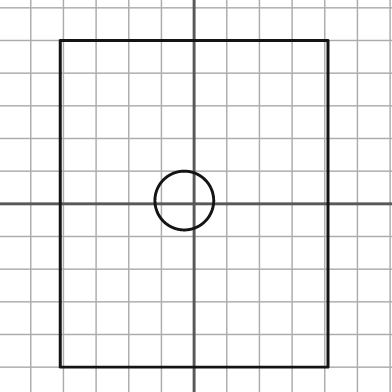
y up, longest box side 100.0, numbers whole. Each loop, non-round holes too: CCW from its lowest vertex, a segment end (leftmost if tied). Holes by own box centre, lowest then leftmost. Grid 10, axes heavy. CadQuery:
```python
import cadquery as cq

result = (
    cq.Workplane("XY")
    .moveTo(-41.0, -50.0)
    .lineTo(41.0, -50.0)
    .lineTo(41.0, 50.0)
    .lineTo(-41.0, 50.0)
    .close()
    .moveTo(-3.0, 1.0)
    .circle(9.0)
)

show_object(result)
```